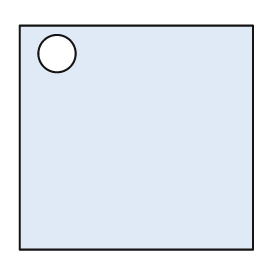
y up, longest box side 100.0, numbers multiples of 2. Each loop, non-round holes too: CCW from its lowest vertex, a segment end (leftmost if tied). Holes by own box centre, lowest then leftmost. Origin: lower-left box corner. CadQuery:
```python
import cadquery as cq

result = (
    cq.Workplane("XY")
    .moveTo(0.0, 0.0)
    .lineTo(100.0, 0.0)
    .lineTo(100.0, 96.0)
    .lineTo(0.0, 96.0)
    .close()
    .moveTo(16.0, 84.0)
    .circle(8.0)
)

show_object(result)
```